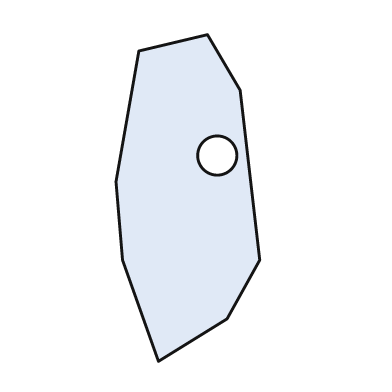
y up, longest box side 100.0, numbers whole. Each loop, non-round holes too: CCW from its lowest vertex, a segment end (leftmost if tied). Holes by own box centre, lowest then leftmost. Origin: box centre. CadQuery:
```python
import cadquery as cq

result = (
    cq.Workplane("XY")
    .moveTo(-9.0, -50.0)
    .lineTo(12.0, -37.0)
    .lineTo(22.0, -19.0)
    .lineTo(16.0, 33.0)
    .lineTo(6.0, 50.0)
    .lineTo(-15.0, 45.0)
    .lineTo(-22.0, 5.0)
    .lineTo(-20.0, -19.0)
    .close()
    .moveTo(9.0, 13.0)
    .circle(6.0)
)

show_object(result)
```